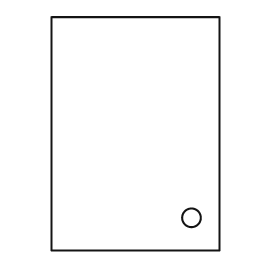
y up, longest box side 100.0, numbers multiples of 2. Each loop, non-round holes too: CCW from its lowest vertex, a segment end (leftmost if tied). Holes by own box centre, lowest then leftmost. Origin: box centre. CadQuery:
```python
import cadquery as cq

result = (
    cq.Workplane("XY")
    .moveTo(-36.0, -50.0)
    .lineTo(36.0, -50.0)
    .lineTo(36.0, 50.0)
    .lineTo(-36.0, 50.0)
    .close()
    .moveTo(24.0, -36.0)
    .circle(4.0)
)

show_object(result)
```